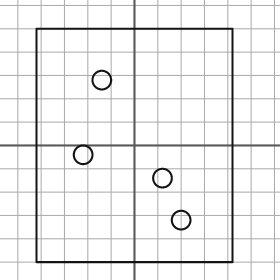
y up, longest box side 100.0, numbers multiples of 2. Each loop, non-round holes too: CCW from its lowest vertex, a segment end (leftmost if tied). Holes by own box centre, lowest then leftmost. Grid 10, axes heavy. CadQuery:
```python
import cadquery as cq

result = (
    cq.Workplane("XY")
    .moveTo(-42.0, -50.0)
    .lineTo(42.0, -50.0)
    .lineTo(42.0, 50.0)
    .lineTo(-42.0, 50.0)
    .close()
    .moveTo(20.0, -32.0)
    .circle(4.0)
    .moveTo(12.0, -14.0)
    .circle(4.0)
    .moveTo(-22.0, -4.0)
    .circle(4.0)
    .moveTo(-14.0, 28.0)
    .circle(4.0)
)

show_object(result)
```